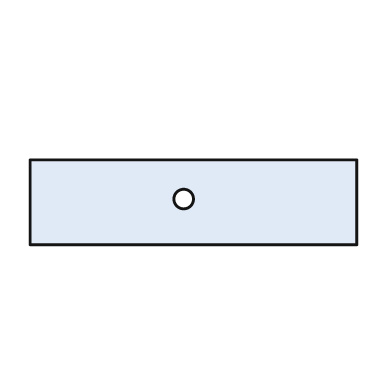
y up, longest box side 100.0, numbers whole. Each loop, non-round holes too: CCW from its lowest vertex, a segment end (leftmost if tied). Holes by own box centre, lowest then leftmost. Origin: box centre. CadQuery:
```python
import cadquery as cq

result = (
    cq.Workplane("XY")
    .moveTo(-50.0, -13.0)
    .lineTo(50.0, -13.0)
    .lineTo(50.0, 13.0)
    .lineTo(-50.0, 13.0)
    .close()
    .moveTo(-3.0, 1.0)
    .circle(3.0)
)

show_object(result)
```